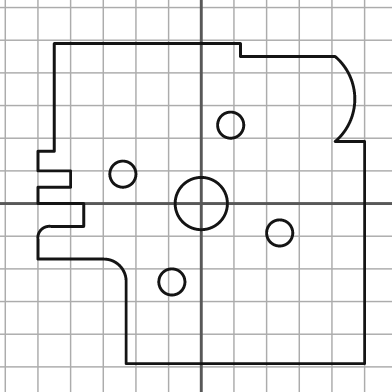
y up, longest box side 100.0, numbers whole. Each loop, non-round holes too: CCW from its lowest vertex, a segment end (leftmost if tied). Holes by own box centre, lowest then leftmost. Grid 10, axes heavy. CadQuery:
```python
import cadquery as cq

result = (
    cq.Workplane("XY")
    .moveTo(-23.0, -49.0)
    .lineTo(50.0, -49.0)
    .lineTo(50.0, 19.0)
    .lineTo(41.0, 19.0)
    .threePointArc((47.0, 32.0), (41.0, 45.0))
    .lineTo(12.0, 45.0)
    .lineTo(12.0, 49.0)
    .lineTo(-45.0, 49.0)
    .lineTo(-45.0, 16.0)
    .lineTo(-50.0, 16.0)
    .lineTo(-50.0, 10.0)
    .lineTo(-40.0, 10.0)
    .lineTo(-40.0, 5.0)
    .lineTo(-50.0, 5.0)
    .lineTo(-50.0, 0.0)
    .lineTo(-36.0, 0.0)
    .lineTo(-36.0, -7.0)
    .lineTo(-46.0, -7.0)
    .threePointArc((-49.0, -8.0), (-50.0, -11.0))
    .lineTo(-50.0, -17.0)
    .lineTo(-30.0, -17.0)
    .threePointArc((-25.0, -19.0), (-23.0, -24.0))
    .close()
    .moveTo(-9.0, -24.0)
    .circle(4.0)
    .moveTo(24.0, -9.0)
    .circle(4.0)
    .moveTo(0.0, 0.0)
    .circle(8.0)
    .moveTo(-24.0, 9.0)
    .circle(4.0)
    .moveTo(9.0, 24.0)
    .circle(4.0)
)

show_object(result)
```